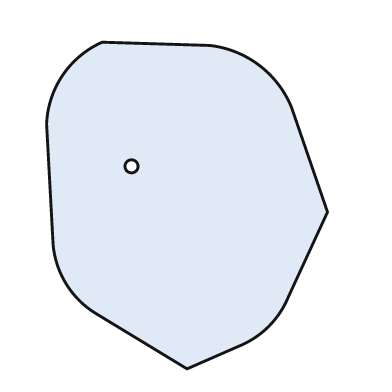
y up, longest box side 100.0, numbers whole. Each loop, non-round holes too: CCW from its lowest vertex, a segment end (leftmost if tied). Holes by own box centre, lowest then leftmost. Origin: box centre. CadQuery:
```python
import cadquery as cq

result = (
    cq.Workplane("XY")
    .moveTo(0.0, -50.0)
    .lineTo(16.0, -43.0)
    .threePointArc((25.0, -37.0), (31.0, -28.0))
    .lineTo(43.0, -2.0)
    .lineTo(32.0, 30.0)
    .threePointArc((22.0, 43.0), (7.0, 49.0))
    .lineTo(-26.0, 50.0)
    .threePointArc((-38.0, 40.0), (-43.0, 25.0))
    .lineTo(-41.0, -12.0)
    .threePointArc((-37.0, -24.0), (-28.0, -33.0))
    .close()
    .moveTo(-17.0, 12.0)
    .circle(2.0)
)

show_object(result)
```